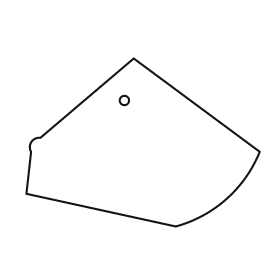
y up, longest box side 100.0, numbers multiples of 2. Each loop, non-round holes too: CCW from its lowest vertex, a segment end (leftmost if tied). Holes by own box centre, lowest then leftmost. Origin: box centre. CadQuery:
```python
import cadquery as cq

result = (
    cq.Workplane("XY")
    .moveTo(14.0, -36.0)
    .threePointArc((36.0, -24.0), (50.0, -4.0))
    .lineTo(-4.0, 36.0)
    .lineTo(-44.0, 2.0)
    .threePointArc((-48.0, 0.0), (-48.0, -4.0))
    .lineTo(-50.0, -22.0)
    .close()
    .moveTo(-8.0, 18.0)
    .circle(2.0)
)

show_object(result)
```